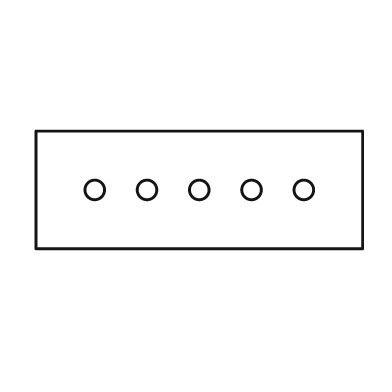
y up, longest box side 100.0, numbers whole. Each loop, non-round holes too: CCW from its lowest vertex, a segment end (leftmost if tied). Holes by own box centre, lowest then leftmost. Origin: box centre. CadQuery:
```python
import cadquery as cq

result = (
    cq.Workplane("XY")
    .moveTo(-50.0, -18.0)
    .lineTo(50.0, -18.0)
    .lineTo(50.0, 18.0)
    .lineTo(-50.0, 18.0)
    .close()
    .moveTo(-32.0, 0.0)
    .circle(3.0)
    .moveTo(-16.0, 0.0)
    .circle(3.0)
    .moveTo(0.0, 0.0)
    .circle(3.0)
    .moveTo(16.0, 0.0)
    .circle(3.0)
    .moveTo(32.0, 0.0)
    .circle(3.0)
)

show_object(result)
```